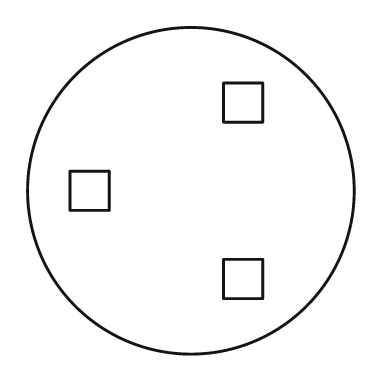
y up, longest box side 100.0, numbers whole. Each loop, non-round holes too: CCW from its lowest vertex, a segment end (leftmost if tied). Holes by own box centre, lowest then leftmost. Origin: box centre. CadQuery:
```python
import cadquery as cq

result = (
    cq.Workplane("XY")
    .moveTo(0.0, 0.0)
    .circle(50.0)
    .moveTo(10.0, -33.0)
    .lineTo(22.0, -33.0)
    .lineTo(22.0, -21.0)
    .lineTo(10.0, -21.0)
    .close()
    .moveTo(-37.0, -6.0)
    .lineTo(-25.0, -6.0)
    .lineTo(-25.0, 6.0)
    .lineTo(-37.0, 6.0)
    .close()
    .moveTo(10.0, 21.0)
    .lineTo(22.0, 21.0)
    .lineTo(22.0, 33.0)
    .lineTo(10.0, 33.0)
    .close()
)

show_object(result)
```